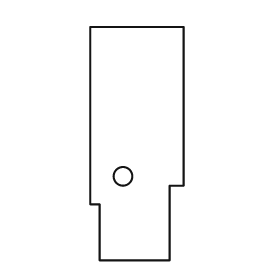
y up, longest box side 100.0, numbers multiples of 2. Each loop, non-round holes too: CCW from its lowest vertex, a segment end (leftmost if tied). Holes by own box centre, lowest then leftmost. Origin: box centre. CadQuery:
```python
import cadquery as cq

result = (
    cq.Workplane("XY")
    .moveTo(-16.0, -50.0)
    .lineTo(14.0, -50.0)
    .lineTo(14.0, -18.0)
    .lineTo(20.0, -18.0)
    .lineTo(20.0, 50.0)
    .lineTo(-20.0, 50.0)
    .lineTo(-20.0, -26.0)
    .lineTo(-16.0, -26.0)
    .close()
    .moveTo(-6.0, -14.0)
    .circle(4.0)
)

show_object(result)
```